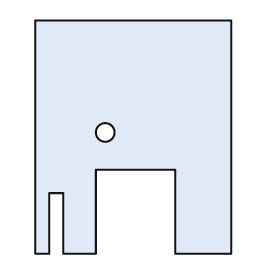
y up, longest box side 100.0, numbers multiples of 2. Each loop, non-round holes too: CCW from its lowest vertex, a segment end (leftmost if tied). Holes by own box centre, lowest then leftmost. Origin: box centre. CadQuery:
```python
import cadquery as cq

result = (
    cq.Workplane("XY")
    .moveTo(-42.0, -50.0)
    .lineTo(-36.0, -50.0)
    .lineTo(-36.0, -24.0)
    .lineTo(-30.0, -24.0)
    .lineTo(-30.0, -50.0)
    .lineTo(-16.0, -50.0)
    .lineTo(-16.0, -14.0)
    .lineTo(18.0, -14.0)
    .lineTo(18.0, -50.0)
    .lineTo(42.0, -50.0)
    .lineTo(42.0, 50.0)
    .lineTo(-42.0, 50.0)
    .close()
    .moveTo(-12.0, 2.0)
    .circle(4.0)
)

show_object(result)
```